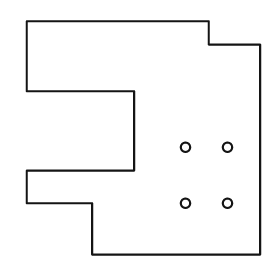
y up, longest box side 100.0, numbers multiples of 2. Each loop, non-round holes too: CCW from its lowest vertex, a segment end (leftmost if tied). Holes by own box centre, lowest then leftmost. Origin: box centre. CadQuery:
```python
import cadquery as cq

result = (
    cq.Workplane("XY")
    .moveTo(-22.0, -50.0)
    .lineTo(50.0, -50.0)
    .lineTo(50.0, 40.0)
    .lineTo(28.0, 40.0)
    .lineTo(28.0, 50.0)
    .lineTo(-50.0, 50.0)
    .lineTo(-50.0, 20.0)
    .lineTo(-4.0, 20.0)
    .lineTo(-4.0, -14.0)
    .lineTo(-50.0, -14.0)
    .lineTo(-50.0, -28.0)
    .lineTo(-22.0, -28.0)
    .close()
    .moveTo(18.0, -28.0)
    .circle(2.0)
    .moveTo(36.0, -28.0)
    .circle(2.0)
    .moveTo(18.0, -4.0)
    .circle(2.0)
    .moveTo(36.0, -4.0)
    .circle(2.0)
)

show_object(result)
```